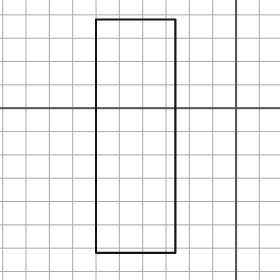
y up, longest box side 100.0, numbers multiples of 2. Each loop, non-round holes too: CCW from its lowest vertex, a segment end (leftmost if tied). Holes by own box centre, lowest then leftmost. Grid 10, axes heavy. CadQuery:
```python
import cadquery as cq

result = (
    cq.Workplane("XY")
    .moveTo(-60.0, -62.0)
    .lineTo(-26.0, -62.0)
    .lineTo(-26.0, 38.0)
    .lineTo(-60.0, 38.0)
    .close()
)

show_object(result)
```